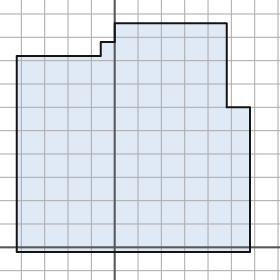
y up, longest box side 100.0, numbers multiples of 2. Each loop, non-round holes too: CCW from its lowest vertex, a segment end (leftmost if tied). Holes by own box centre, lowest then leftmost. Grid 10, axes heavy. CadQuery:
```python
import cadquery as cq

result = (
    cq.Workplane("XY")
    .moveTo(-42.0, -2.0)
    .lineTo(58.0, -2.0)
    .lineTo(58.0, 60.0)
    .lineTo(48.0, 60.0)
    .lineTo(48.0, 96.0)
    .lineTo(0.0, 96.0)
    .lineTo(0.0, 88.0)
    .lineTo(-6.0, 88.0)
    .lineTo(-6.0, 82.0)
    .lineTo(-42.0, 82.0)
    .close()
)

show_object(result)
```